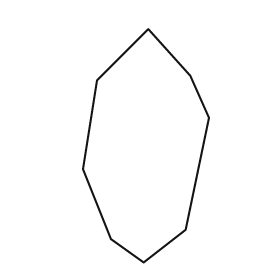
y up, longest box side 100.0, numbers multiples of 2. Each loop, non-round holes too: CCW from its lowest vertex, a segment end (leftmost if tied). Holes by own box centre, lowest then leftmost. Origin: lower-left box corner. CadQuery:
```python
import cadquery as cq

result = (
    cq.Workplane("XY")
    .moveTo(26.0, 0.0)
    .lineTo(44.0, 14.0)
    .lineTo(54.0, 62.0)
    .lineTo(46.0, 80.0)
    .lineTo(28.0, 100.0)
    .lineTo(6.0, 78.0)
    .lineTo(0.0, 40.0)
    .lineTo(12.0, 10.0)
    .close()
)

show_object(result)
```